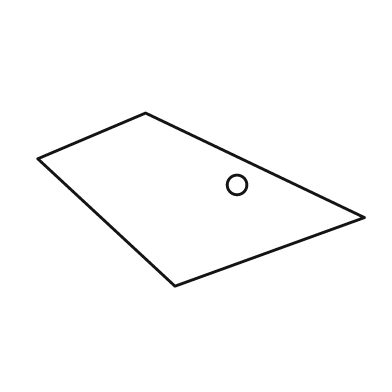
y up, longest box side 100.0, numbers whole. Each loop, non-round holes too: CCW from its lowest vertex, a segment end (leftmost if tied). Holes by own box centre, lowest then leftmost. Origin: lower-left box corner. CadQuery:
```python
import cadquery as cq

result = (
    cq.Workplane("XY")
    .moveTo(42.0, 0.0)
    .lineTo(100.0, 21.0)
    .lineTo(33.0, 53.0)
    .lineTo(0.0, 39.0)
    .close()
    .moveTo(61.0, 31.0)
    .circle(3.0)
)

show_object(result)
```